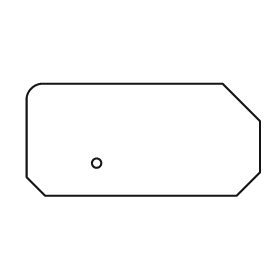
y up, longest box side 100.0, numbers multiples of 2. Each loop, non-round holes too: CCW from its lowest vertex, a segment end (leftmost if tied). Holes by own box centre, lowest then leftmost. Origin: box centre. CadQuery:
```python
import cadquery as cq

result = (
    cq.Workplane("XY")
    .moveTo(-42.0, -24.0)
    .lineTo(40.0, -24.0)
    .lineTo(50.0, -14.0)
    .lineTo(50.0, 8.0)
    .lineTo(34.0, 24.0)
    .lineTo(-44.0, 24.0)
    .threePointArc((-48.0, 22.0), (-50.0, 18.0))
    .lineTo(-50.0, -16.0)
    .close()
    .moveTo(-20.0, -10.0)
    .circle(2.0)
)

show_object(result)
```